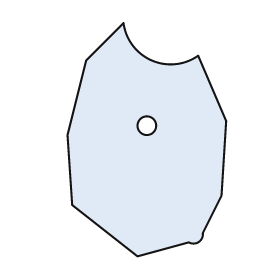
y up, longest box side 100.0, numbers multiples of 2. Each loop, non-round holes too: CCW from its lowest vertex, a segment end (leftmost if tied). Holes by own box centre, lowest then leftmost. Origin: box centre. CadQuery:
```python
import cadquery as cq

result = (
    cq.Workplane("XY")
    .moveTo(-4.0, -50.0)
    .lineTo(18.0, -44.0)
    .threePointArc((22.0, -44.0), (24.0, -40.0))
    .lineTo(32.0, -24.0)
    .lineTo(34.0, 8.0)
    .lineTo(22.0, 36.0)
    .threePointArc((2.0, 34.0), (-10.0, 50.0))
    .lineTo(-26.0, 34.0)
    .lineTo(-34.0, 2.0)
    .lineTo(-32.0, -28.0)
    .close()
    .moveTo(0.0, 6.0)
    .circle(4.0)
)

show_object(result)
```